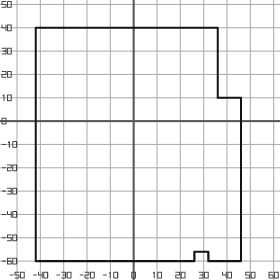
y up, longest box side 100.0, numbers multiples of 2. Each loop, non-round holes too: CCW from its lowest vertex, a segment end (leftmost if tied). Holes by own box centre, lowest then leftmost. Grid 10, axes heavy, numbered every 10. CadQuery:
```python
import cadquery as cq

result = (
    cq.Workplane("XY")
    .moveTo(-42.0, -60.0)
    .lineTo(26.0, -60.0)
    .lineTo(26.0, -56.0)
    .lineTo(32.0, -56.0)
    .lineTo(32.0, -60.0)
    .lineTo(46.0, -60.0)
    .lineTo(46.0, 10.0)
    .lineTo(36.0, 10.0)
    .lineTo(36.0, 40.0)
    .lineTo(-42.0, 40.0)
    .close()
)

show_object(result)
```